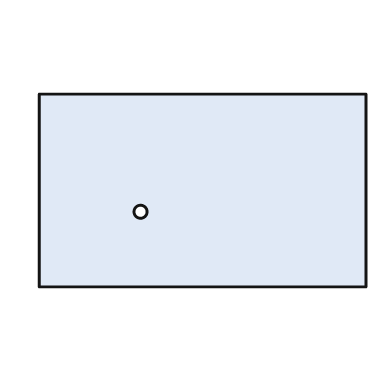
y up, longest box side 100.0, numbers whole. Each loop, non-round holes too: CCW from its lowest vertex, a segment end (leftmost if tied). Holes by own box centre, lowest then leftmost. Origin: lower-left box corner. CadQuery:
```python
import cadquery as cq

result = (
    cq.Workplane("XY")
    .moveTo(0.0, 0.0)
    .lineTo(100.0, 0.0)
    .lineTo(100.0, 59.0)
    .lineTo(0.0, 59.0)
    .close()
    .moveTo(31.0, 23.0)
    .circle(2.0)
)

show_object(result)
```